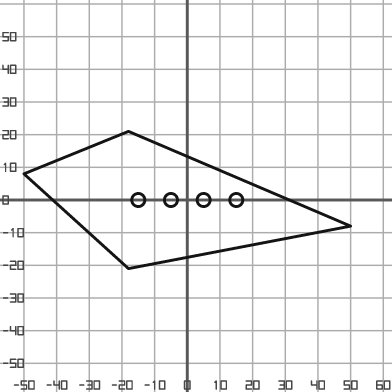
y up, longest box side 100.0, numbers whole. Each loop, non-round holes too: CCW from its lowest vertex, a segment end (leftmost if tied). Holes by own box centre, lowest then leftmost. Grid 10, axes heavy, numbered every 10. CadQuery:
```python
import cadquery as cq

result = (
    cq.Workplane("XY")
    .moveTo(-18.0, -21.0)
    .lineTo(50.0, -8.0)
    .lineTo(-18.0, 21.0)
    .lineTo(-50.0, 8.0)
    .close()
    .moveTo(-15.0, 0.0)
    .circle(2.0)
    .moveTo(-5.0, 0.0)
    .circle(2.0)
    .moveTo(5.0, 0.0)
    .circle(2.0)
    .moveTo(15.0, 0.0)
    .circle(2.0)
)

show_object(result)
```